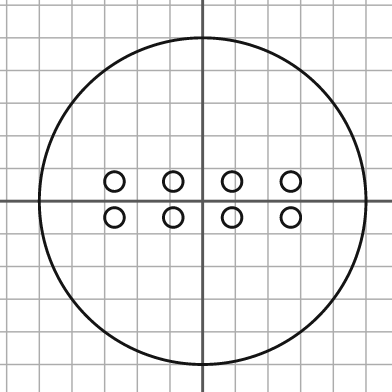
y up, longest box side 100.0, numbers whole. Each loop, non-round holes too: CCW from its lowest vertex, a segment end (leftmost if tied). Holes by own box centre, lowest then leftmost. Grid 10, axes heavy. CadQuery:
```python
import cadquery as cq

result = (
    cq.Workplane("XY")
    .moveTo(0.0, 0.0)
    .circle(50.0)
    .moveTo(-27.0, -5.0)
    .circle(3.0)
    .moveTo(-9.0, -5.0)
    .circle(3.0)
    .moveTo(9.0, -5.0)
    .circle(3.0)
    .moveTo(27.0, -5.0)
    .circle(3.0)
    .moveTo(-27.0, 6.0)
    .circle(3.0)
    .moveTo(-9.0, 6.0)
    .circle(3.0)
    .moveTo(9.0, 6.0)
    .circle(3.0)
    .moveTo(27.0, 6.0)
    .circle(3.0)
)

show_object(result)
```